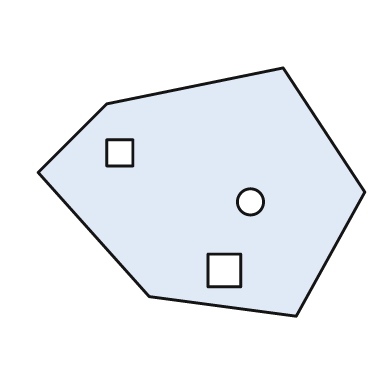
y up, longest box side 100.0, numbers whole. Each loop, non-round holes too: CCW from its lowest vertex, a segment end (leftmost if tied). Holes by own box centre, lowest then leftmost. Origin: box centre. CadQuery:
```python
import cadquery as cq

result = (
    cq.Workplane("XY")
    .moveTo(29.0, -38.0)
    .lineTo(50.0, 0.0)
    .lineTo(25.0, 38.0)
    .lineTo(-29.0, 27.0)
    .lineTo(-50.0, 6.0)
    .lineTo(-16.0, -32.0)
    .close()
    .moveTo(2.0, -29.0)
    .lineTo(12.0, -29.0)
    .lineTo(12.0, -19.0)
    .lineTo(2.0, -19.0)
    .close()
    .moveTo(15.0, -3.0)
    .circle(4.0)
    .moveTo(-29.0, 8.0)
    .lineTo(-21.0, 8.0)
    .lineTo(-21.0, 16.0)
    .lineTo(-29.0, 16.0)
    .close()
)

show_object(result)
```